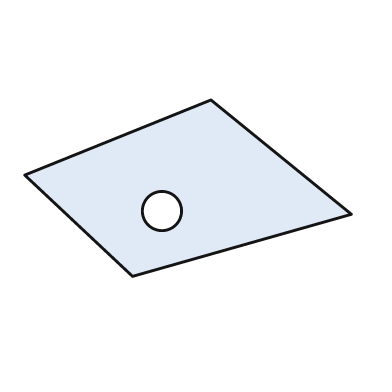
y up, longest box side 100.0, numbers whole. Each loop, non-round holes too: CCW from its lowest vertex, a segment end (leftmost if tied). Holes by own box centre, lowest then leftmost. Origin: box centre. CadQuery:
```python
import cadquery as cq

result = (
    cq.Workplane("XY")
    .moveTo(-17.0, -27.0)
    .lineTo(50.0, -8.0)
    .lineTo(7.0, 27.0)
    .lineTo(-50.0, 4.0)
    .close()
    .moveTo(-8.0, -7.0)
    .circle(6.0)
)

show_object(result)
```